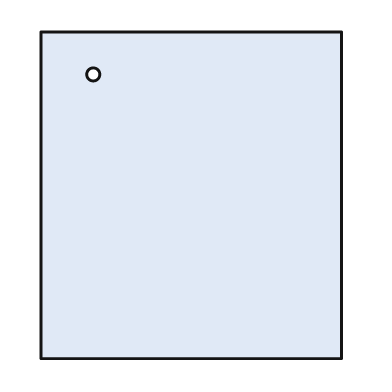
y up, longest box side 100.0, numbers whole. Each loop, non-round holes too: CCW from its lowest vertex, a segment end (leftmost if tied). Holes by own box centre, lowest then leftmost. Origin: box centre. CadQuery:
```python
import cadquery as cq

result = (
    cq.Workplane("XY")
    .moveTo(-46.0, -50.0)
    .lineTo(46.0, -50.0)
    .lineTo(46.0, 50.0)
    .lineTo(-46.0, 50.0)
    .close()
    .moveTo(-30.0, 37.0)
    .circle(2.0)
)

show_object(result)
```